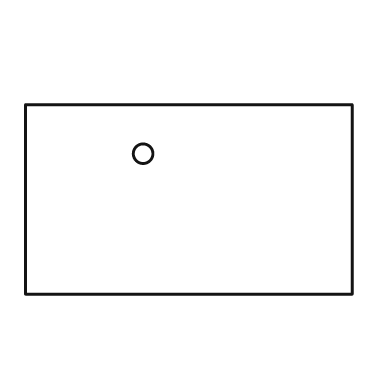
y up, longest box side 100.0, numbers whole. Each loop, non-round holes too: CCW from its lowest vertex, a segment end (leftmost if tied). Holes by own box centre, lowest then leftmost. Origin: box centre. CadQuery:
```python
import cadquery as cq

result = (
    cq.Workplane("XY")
    .moveTo(-50.0, -29.0)
    .lineTo(50.0, -29.0)
    .lineTo(50.0, 29.0)
    .lineTo(-50.0, 29.0)
    .close()
    .moveTo(-14.0, 14.0)
    .circle(3.0)
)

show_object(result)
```